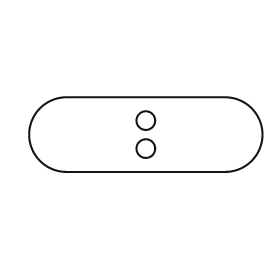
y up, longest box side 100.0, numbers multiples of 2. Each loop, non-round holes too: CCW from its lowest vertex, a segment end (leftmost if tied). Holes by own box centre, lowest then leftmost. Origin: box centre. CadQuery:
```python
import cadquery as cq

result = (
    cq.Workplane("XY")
    .moveTo(-34.0, -16.0)
    .lineTo(34.0, -16.0)
    .threePointArc((50.0, 0.0), (34.0, 16.0))
    .lineTo(-34.0, 16.0)
    .threePointArc((-50.0, 0.0), (-34.0, -16.0))
    .close()
    .moveTo(0.0, -6.0)
    .circle(4.0)
    .moveTo(0.0, 6.0)
    .circle(4.0)
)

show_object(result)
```